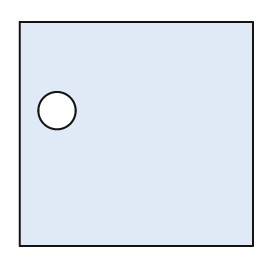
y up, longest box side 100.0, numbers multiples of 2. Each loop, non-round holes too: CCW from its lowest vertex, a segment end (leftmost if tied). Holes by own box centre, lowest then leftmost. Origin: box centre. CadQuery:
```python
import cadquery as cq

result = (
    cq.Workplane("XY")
    .moveTo(-50.0, -48.0)
    .lineTo(50.0, -48.0)
    .lineTo(50.0, 48.0)
    .lineTo(-50.0, 48.0)
    .close()
    .moveTo(-34.0, 10.0)
    .circle(8.0)
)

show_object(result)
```